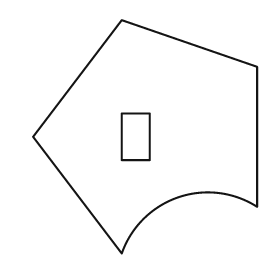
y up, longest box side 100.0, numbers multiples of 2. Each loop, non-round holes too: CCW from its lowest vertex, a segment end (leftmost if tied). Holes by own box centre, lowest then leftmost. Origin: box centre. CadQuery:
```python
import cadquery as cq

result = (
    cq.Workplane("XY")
    .moveTo(-10.0, -50.0)
    .threePointArc((14.0, -26.0), (48.0, -30.0))
    .lineTo(48.0, 30.0)
    .lineTo(-10.0, 50.0)
    .lineTo(-48.0, 0.0)
    .close()
    .moveTo(-10.0, -10.0)
    .lineTo(2.0, -10.0)
    .lineTo(2.0, 10.0)
    .lineTo(-10.0, 10.0)
    .close()
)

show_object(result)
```